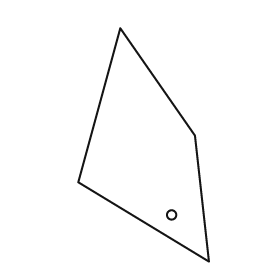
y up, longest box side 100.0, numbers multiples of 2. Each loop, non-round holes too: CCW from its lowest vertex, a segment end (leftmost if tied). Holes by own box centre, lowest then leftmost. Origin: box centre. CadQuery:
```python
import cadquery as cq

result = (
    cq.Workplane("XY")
    .moveTo(28.0, -50.0)
    .lineTo(22.0, 4.0)
    .lineTo(-10.0, 50.0)
    .lineTo(-28.0, -16.0)
    .close()
    .moveTo(12.0, -30.0)
    .circle(2.0)
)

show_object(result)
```